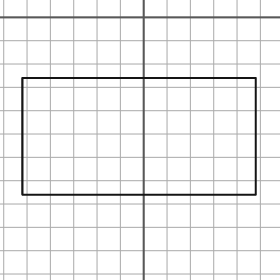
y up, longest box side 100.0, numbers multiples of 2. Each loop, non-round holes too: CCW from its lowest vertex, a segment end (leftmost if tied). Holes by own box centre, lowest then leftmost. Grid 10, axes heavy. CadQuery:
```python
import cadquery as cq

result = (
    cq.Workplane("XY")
    .moveTo(-52.0, -76.0)
    .lineTo(48.0, -76.0)
    .lineTo(48.0, -26.0)
    .lineTo(-52.0, -26.0)
    .close()
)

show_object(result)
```